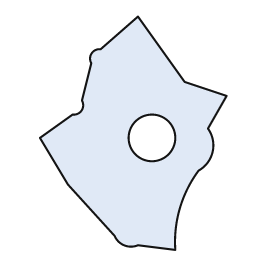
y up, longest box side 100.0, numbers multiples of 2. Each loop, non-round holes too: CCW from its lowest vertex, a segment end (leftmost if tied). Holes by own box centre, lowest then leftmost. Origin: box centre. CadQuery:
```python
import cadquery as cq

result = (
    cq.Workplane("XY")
    .moveTo(18.0, -50.0)
    .threePointArc((20.0, -32.0), (28.0, -16.0))
    .threePointArc((34.0, -8.0), (32.0, 2.0))
    .lineTo(40.0, 16.0)
    .lineTo(22.0, 22.0)
    .lineTo(2.0, 50.0)
    .lineTo(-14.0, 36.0)
    .threePointArc((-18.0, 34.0), (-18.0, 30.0))
    .lineTo(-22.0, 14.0)
    .threePointArc((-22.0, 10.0), (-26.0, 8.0))
    .lineTo(-40.0, -2.0)
    .lineTo(-28.0, -22.0)
    .lineTo(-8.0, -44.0)
    .threePointArc((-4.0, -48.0), (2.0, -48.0))
    .close()
    .moveTo(8.0, -2.0)
    .circle(10.0)
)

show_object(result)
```